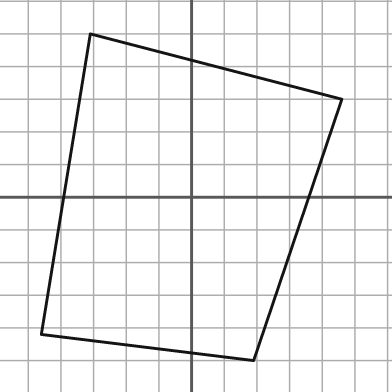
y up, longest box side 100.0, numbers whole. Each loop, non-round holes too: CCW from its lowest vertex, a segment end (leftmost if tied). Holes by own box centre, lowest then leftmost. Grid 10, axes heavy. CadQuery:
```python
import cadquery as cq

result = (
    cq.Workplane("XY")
    .moveTo(19.0, -50.0)
    .lineTo(46.0, 30.0)
    .lineTo(-31.0, 50.0)
    .lineTo(-46.0, -42.0)
    .close()
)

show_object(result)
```